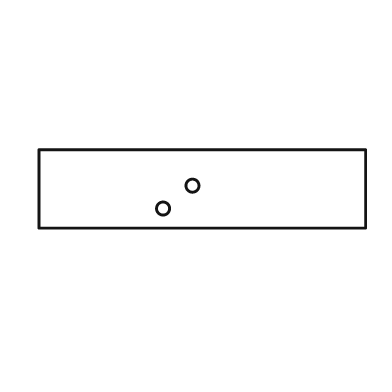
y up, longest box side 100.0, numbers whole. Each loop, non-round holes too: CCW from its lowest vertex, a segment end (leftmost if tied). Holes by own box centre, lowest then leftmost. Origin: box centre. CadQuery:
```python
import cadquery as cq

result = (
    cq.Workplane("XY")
    .moveTo(-50.0, -12.0)
    .lineTo(50.0, -12.0)
    .lineTo(50.0, 12.0)
    .lineTo(-50.0, 12.0)
    .close()
    .moveTo(-12.0, -6.0)
    .circle(2.0)
    .moveTo(-3.0, 1.0)
    .circle(2.0)
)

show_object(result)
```